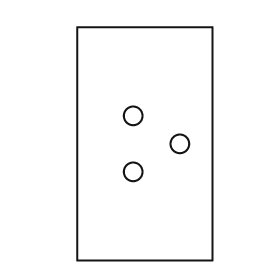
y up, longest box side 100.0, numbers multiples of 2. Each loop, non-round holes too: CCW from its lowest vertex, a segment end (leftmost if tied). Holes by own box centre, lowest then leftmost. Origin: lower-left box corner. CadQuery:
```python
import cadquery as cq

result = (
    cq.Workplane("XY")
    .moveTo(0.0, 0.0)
    .lineTo(58.0, 0.0)
    .lineTo(58.0, 100.0)
    .lineTo(0.0, 100.0)
    .close()
    .moveTo(24.0, 38.0)
    .circle(4.0)
    .moveTo(44.0, 50.0)
    .circle(4.0)
    .moveTo(24.0, 62.0)
    .circle(4.0)
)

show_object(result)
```